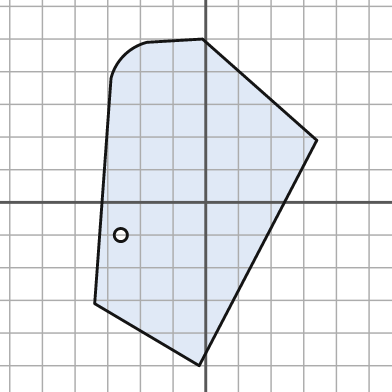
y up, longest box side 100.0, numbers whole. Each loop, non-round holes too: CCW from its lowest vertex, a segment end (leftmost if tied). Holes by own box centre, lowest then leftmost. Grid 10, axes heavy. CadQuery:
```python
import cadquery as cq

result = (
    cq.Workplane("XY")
    .moveTo(-2.0, -50.0)
    .lineTo(34.0, 19.0)
    .lineTo(-1.0, 50.0)
    .lineTo(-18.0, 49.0)
    .threePointArc((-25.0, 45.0), (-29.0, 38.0))
    .lineTo(-34.0, -31.0)
    .close()
    .moveTo(-26.0, -10.0)
    .circle(2.0)
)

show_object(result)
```